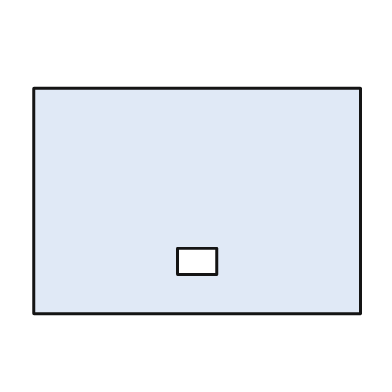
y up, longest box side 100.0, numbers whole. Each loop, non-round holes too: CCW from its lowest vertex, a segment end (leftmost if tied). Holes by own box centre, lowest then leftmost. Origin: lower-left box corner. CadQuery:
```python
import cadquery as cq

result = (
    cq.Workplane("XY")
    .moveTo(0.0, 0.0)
    .lineTo(100.0, 0.0)
    .lineTo(100.0, 69.0)
    .lineTo(0.0, 69.0)
    .close()
    .moveTo(44.0, 12.0)
    .lineTo(56.0, 12.0)
    .lineTo(56.0, 20.0)
    .lineTo(44.0, 20.0)
    .close()
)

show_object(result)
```